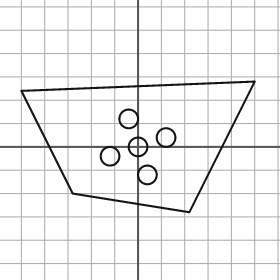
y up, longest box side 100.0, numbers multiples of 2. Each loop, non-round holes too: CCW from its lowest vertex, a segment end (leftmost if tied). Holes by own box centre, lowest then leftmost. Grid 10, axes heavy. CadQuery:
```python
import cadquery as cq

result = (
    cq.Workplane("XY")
    .moveTo(22.0, -28.0)
    .lineTo(50.0, 28.0)
    .lineTo(-50.0, 24.0)
    .lineTo(-28.0, -20.0)
    .close()
    .moveTo(4.0, -12.0)
    .circle(4.0)
    .moveTo(-12.0, -4.0)
    .circle(4.0)
    .moveTo(0.0, 0.0)
    .circle(4.0)
    .moveTo(12.0, 4.0)
    .circle(4.0)
    .moveTo(-4.0, 12.0)
    .circle(4.0)
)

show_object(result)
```